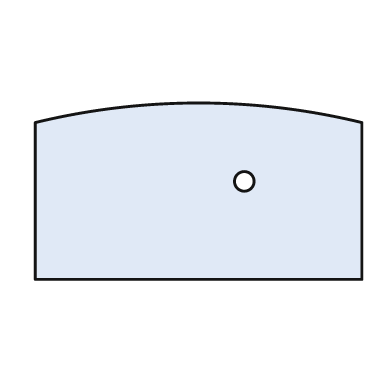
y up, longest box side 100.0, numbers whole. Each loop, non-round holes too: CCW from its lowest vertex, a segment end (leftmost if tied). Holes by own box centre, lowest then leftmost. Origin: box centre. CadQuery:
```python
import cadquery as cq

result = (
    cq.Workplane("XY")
    .moveTo(-50.0, -27.0)
    .lineTo(50.0, -27.0)
    .lineTo(50.0, 21.0)
    .threePointArc((0.0, 27.0), (-50.0, 21.0))
    .close()
    .moveTo(14.0, 3.0)
    .circle(3.0)
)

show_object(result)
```